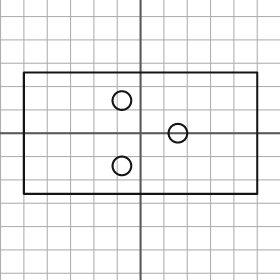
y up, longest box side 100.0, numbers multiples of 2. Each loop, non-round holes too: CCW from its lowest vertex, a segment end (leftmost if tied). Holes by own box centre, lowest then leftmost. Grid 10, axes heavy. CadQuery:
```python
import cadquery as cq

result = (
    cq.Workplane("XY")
    .moveTo(-50.0, -26.0)
    .lineTo(50.0, -26.0)
    .lineTo(50.0, 26.0)
    .lineTo(-50.0, 26.0)
    .close()
    .moveTo(-8.0, -14.0)
    .circle(4.0)
    .moveTo(16.0, 0.0)
    .circle(4.0)
    .moveTo(-8.0, 14.0)
    .circle(4.0)
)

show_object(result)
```